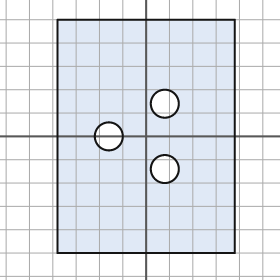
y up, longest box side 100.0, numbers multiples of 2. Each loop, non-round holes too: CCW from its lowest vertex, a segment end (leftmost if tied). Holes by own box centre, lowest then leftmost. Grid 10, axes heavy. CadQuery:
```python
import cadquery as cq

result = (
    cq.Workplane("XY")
    .moveTo(-38.0, -50.0)
    .lineTo(38.0, -50.0)
    .lineTo(38.0, 50.0)
    .lineTo(-38.0, 50.0)
    .close()
    .moveTo(8.0, -14.0)
    .circle(6.0)
    .moveTo(-16.0, 0.0)
    .circle(6.0)
    .moveTo(8.0, 14.0)
    .circle(6.0)
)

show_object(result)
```